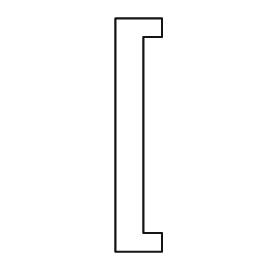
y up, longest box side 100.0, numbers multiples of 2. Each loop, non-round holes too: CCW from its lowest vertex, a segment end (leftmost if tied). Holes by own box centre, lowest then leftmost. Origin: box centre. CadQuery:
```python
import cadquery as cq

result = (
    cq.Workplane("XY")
    .moveTo(-10.0, -50.0)
    .lineTo(10.0, -50.0)
    .lineTo(10.0, -42.0)
    .lineTo(2.0, -42.0)
    .lineTo(2.0, 42.0)
    .lineTo(10.0, 42.0)
    .lineTo(10.0, 50.0)
    .lineTo(-10.0, 50.0)
    .close()
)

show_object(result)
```